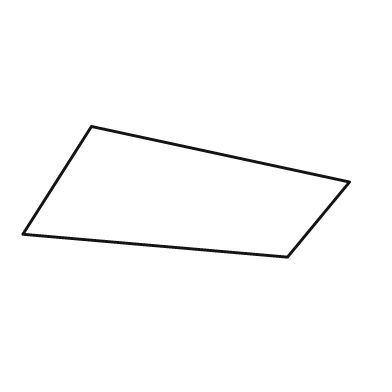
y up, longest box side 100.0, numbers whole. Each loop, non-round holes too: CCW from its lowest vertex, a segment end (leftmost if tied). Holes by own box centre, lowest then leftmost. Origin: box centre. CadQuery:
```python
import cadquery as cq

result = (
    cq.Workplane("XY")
    .moveTo(31.0, -20.0)
    .lineTo(50.0, 3.0)
    .lineTo(-29.0, 20.0)
    .lineTo(-50.0, -13.0)
    .close()
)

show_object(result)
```